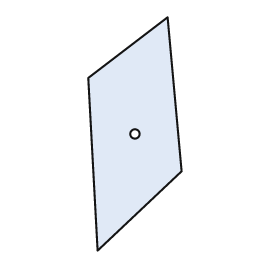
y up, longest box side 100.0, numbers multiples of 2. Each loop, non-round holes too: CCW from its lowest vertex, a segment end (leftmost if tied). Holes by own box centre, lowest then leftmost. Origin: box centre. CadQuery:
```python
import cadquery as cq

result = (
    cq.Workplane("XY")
    .moveTo(-16.0, -50.0)
    .lineTo(20.0, -16.0)
    .lineTo(14.0, 50.0)
    .lineTo(-20.0, 24.0)
    .close()
    .moveTo(0.0, 0.0)
    .circle(2.0)
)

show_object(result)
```